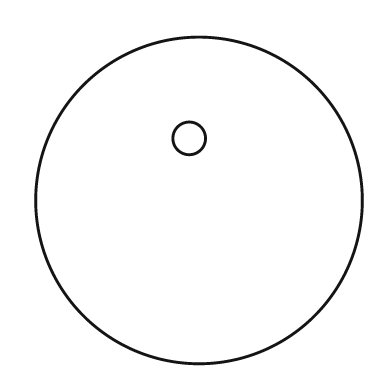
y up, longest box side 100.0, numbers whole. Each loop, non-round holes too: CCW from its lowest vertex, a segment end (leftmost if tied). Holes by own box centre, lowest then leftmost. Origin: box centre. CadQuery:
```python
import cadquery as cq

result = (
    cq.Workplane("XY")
    .moveTo(0.0, 0.0)
    .circle(50.0)
    .moveTo(-3.0, 19.0)
    .circle(5.0)
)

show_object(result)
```